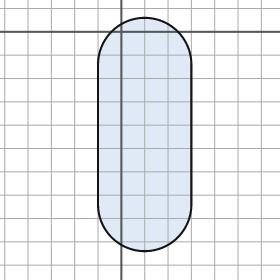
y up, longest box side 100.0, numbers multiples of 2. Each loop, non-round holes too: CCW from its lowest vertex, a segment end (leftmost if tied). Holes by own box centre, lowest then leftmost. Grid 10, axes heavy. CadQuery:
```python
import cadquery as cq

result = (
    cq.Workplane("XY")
    .moveTo(-10.0, -74.0)
    .threePointArc((10.0, -94.0), (30.0, -74.0))
    .lineTo(30.0, -14.0)
    .threePointArc((10.0, 6.0), (-10.0, -14.0))
    .close()
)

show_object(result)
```